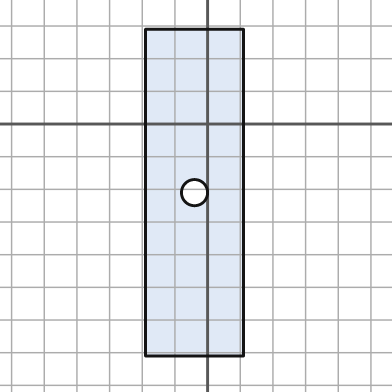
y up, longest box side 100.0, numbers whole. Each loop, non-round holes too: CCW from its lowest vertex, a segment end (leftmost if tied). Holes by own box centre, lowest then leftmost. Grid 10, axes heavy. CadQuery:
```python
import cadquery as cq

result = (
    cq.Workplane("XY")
    .moveTo(-19.0, -71.0)
    .lineTo(11.0, -71.0)
    .lineTo(11.0, 29.0)
    .lineTo(-19.0, 29.0)
    .close()
    .moveTo(-4.0, -21.0)
    .circle(4.0)
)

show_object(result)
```